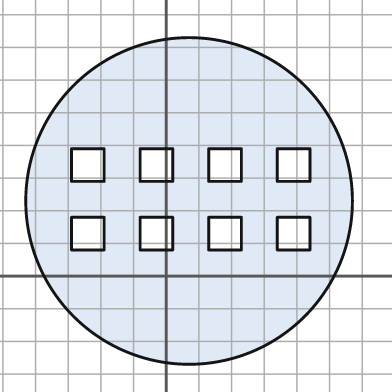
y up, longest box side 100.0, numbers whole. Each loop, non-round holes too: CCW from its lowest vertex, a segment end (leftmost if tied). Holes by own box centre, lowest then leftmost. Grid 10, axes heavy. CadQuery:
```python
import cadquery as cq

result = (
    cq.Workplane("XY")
    .moveTo(7.0, 23.0)
    .circle(50.0)
    .moveTo(-29.0, 8.0)
    .lineTo(-19.0, 8.0)
    .lineTo(-19.0, 18.0)
    .lineTo(-29.0, 18.0)
    .close()
    .moveTo(-8.0, 8.0)
    .lineTo(2.0, 8.0)
    .lineTo(2.0, 18.0)
    .lineTo(-8.0, 18.0)
    .close()
    .moveTo(13.0, 8.0)
    .lineTo(23.0, 8.0)
    .lineTo(23.0, 18.0)
    .lineTo(13.0, 18.0)
    .close()
    .moveTo(34.0, 8.0)
    .lineTo(44.0, 8.0)
    .lineTo(44.0, 18.0)
    .lineTo(34.0, 18.0)
    .close()
    .moveTo(-29.0, 29.0)
    .lineTo(-19.0, 29.0)
    .lineTo(-19.0, 39.0)
    .lineTo(-29.0, 39.0)
    .close()
    .moveTo(-8.0, 29.0)
    .lineTo(2.0, 29.0)
    .lineTo(2.0, 39.0)
    .lineTo(-8.0, 39.0)
    .close()
    .moveTo(13.0, 29.0)
    .lineTo(23.0, 29.0)
    .lineTo(23.0, 39.0)
    .lineTo(13.0, 39.0)
    .close()
    .moveTo(34.0, 29.0)
    .lineTo(44.0, 29.0)
    .lineTo(44.0, 39.0)
    .lineTo(34.0, 39.0)
    .close()
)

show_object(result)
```